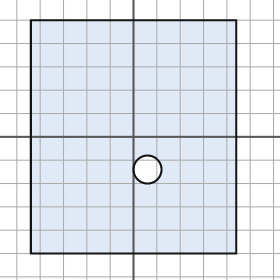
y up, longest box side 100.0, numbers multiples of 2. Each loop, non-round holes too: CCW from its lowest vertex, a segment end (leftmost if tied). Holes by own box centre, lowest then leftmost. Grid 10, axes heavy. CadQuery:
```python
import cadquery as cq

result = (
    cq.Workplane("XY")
    .moveTo(-44.0, -50.0)
    .lineTo(44.0, -50.0)
    .lineTo(44.0, 50.0)
    .lineTo(-44.0, 50.0)
    .close()
    .moveTo(6.0, -14.0)
    .circle(6.0)
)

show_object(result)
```